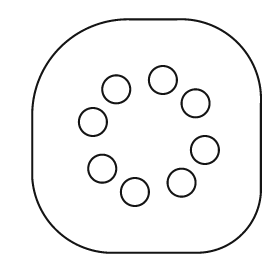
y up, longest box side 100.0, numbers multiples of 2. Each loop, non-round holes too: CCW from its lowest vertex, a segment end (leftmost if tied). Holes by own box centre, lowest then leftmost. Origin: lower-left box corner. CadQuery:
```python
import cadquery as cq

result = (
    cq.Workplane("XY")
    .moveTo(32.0, 0.0)
    .lineTo(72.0, 0.0)
    .threePointArc((90.0, 8.0), (98.0, 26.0))
    .lineTo(98.0, 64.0)
    .threePointArc((88.0, 90.0), (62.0, 100.0))
    .lineTo(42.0, 100.0)
    .threePointArc((12.0, 88.0), (0.0, 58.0))
    .lineTo(0.0, 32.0)
    .threePointArc((10.0, 10.0), (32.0, 0.0))
    .close()
    .moveTo(44.0, 26.0)
    .circle(6.0)
    .moveTo(64.0, 30.0)
    .circle(6.0)
    .moveTo(30.0, 36.0)
    .circle(6.0)
    .moveTo(74.0, 44.0)
    .circle(6.0)
    .moveTo(26.0, 56.0)
    .circle(6.0)
    .moveTo(70.0, 64.0)
    .circle(6.0)
    .moveTo(36.0, 70.0)
    .circle(6.0)
    .moveTo(56.0, 74.0)
    .circle(6.0)
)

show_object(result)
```